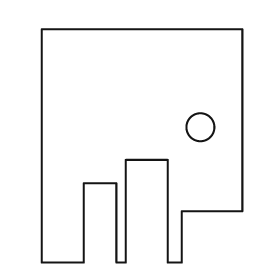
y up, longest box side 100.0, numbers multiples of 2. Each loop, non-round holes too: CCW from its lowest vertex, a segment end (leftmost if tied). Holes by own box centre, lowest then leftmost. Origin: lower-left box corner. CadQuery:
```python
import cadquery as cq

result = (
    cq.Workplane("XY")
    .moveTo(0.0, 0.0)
    .lineTo(18.0, 0.0)
    .lineTo(18.0, 34.0)
    .lineTo(32.0, 34.0)
    .lineTo(32.0, 0.0)
    .lineTo(36.0, 0.0)
    .lineTo(36.0, 44.0)
    .lineTo(54.0, 44.0)
    .lineTo(54.0, 0.0)
    .lineTo(60.0, 0.0)
    .lineTo(60.0, 22.0)
    .lineTo(86.0, 22.0)
    .lineTo(86.0, 100.0)
    .lineTo(0.0, 100.0)
    .close()
    .moveTo(68.0, 58.0)
    .circle(6.0)
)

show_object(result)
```